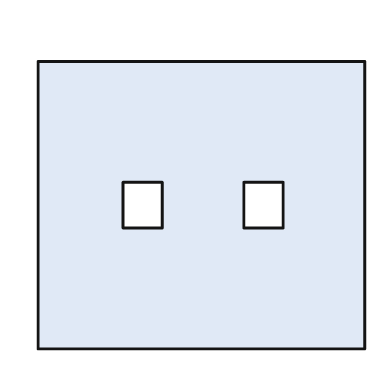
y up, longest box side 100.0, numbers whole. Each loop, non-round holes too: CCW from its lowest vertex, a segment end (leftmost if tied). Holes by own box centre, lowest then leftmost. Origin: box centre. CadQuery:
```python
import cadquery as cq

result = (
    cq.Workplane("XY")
    .moveTo(-50.0, -44.0)
    .lineTo(50.0, -44.0)
    .lineTo(50.0, 44.0)
    .lineTo(-50.0, 44.0)
    .close()
    .moveTo(-24.0, -7.0)
    .lineTo(-12.0, -7.0)
    .lineTo(-12.0, 7.0)
    .lineTo(-24.0, 7.0)
    .close()
    .moveTo(13.0, -7.0)
    .lineTo(25.0, -7.0)
    .lineTo(25.0, 7.0)
    .lineTo(13.0, 7.0)
    .close()
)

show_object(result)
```